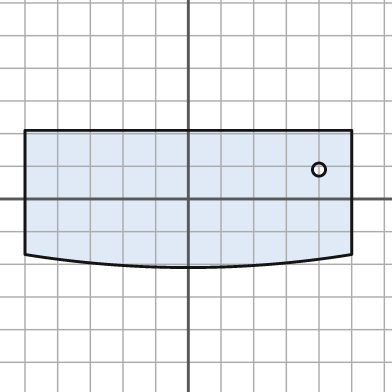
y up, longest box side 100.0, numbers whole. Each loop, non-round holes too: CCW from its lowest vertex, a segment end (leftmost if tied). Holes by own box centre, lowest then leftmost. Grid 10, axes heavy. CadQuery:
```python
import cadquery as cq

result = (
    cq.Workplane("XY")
    .moveTo(-50.0, -17.0)
    .threePointArc((0.0, -21.0), (50.0, -17.0))
    .lineTo(50.0, 21.0)
    .lineTo(-50.0, 21.0)
    .close()
    .moveTo(40.0, 9.0)
    .circle(2.0)
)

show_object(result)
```